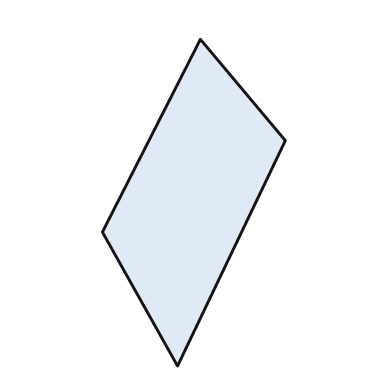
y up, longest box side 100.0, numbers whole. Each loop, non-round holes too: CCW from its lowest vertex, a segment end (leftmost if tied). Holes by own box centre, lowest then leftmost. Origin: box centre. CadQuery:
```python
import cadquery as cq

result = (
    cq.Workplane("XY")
    .moveTo(-5.0, -50.0)
    .lineTo(28.0, 19.0)
    .lineTo(2.0, 50.0)
    .lineTo(-28.0, -9.0)
    .close()
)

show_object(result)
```